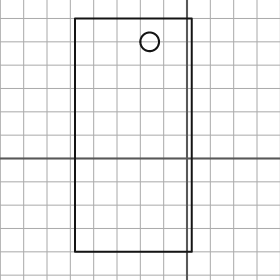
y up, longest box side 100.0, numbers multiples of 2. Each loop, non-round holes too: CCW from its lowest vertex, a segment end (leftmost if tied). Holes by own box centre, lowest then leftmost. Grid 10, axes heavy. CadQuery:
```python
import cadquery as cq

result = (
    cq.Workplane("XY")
    .moveTo(-48.0, -40.0)
    .lineTo(2.0, -40.0)
    .lineTo(2.0, 60.0)
    .lineTo(-48.0, 60.0)
    .close()
    .moveTo(-16.0, 50.0)
    .circle(4.0)
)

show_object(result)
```